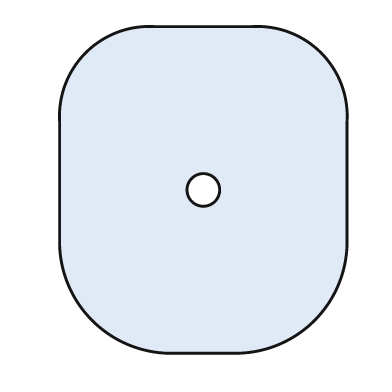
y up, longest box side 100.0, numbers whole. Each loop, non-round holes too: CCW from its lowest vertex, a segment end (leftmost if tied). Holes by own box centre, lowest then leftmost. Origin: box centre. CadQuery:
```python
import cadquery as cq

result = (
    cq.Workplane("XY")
    .moveTo(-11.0, -50.0)
    .lineTo(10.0, -50.0)
    .threePointArc((34.0, -40.0), (44.0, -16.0))
    .lineTo(44.0, 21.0)
    .threePointArc((36.0, 42.0), (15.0, 50.0))
    .lineTo(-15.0, 50.0)
    .threePointArc((-36.0, 42.0), (-44.0, 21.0))
    .lineTo(-44.0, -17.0)
    .threePointArc((-34.0, -40.0), (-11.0, -50.0))
    .close()
    .moveTo(0.0, 0.0)
    .circle(5.0)
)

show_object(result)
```